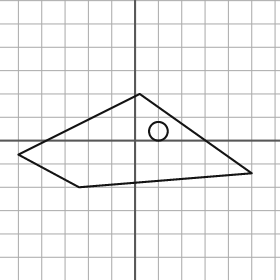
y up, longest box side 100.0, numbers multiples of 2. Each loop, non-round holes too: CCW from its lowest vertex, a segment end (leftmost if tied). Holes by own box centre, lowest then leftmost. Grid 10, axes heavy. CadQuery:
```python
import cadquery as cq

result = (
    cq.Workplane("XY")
    .moveTo(-24.0, -20.0)
    .lineTo(50.0, -14.0)
    .lineTo(2.0, 20.0)
    .lineTo(-50.0, -6.0)
    .close()
    .moveTo(10.0, 4.0)
    .circle(4.0)
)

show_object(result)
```